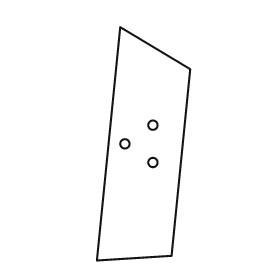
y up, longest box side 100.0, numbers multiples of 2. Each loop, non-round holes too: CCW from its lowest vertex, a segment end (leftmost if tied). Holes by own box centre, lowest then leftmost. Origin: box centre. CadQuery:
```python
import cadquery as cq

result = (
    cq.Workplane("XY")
    .moveTo(-20.0, -50.0)
    .lineTo(12.0, -48.0)
    .lineTo(20.0, 32.0)
    .lineTo(-10.0, 50.0)
    .close()
    .moveTo(4.0, -8.0)
    .circle(2.0)
    .moveTo(-8.0, 0.0)
    .circle(2.0)
    .moveTo(4.0, 8.0)
    .circle(2.0)
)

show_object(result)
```